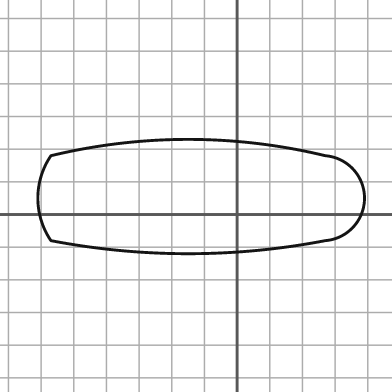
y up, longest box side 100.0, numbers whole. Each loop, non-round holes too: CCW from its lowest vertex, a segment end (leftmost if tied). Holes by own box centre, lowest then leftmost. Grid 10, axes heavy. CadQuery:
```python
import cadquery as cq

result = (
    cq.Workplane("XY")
    .moveTo(-57.0, -8.0)
    .threePointArc((-15.0, -12.0), (27.0, -8.0))
    .threePointArc((39.0, 5.0), (27.0, 18.0))
    .threePointArc((-15.0, 23.0), (-57.0, 18.0))
    .threePointArc((-61.0, 5.0), (-57.0, -8.0))
    .close()
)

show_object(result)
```